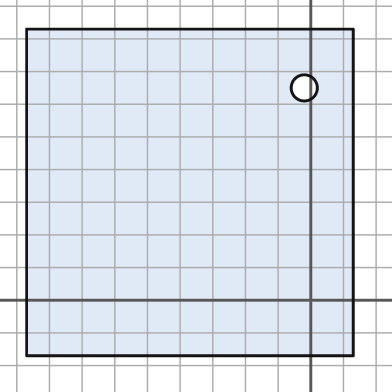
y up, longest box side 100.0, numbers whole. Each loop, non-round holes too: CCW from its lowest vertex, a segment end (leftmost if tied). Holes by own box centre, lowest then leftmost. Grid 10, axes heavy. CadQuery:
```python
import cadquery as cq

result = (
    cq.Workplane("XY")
    .moveTo(-87.0, -17.0)
    .lineTo(13.0, -17.0)
    .lineTo(13.0, 83.0)
    .lineTo(-87.0, 83.0)
    .close()
    .moveTo(-2.0, 65.0)
    .circle(4.0)
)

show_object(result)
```